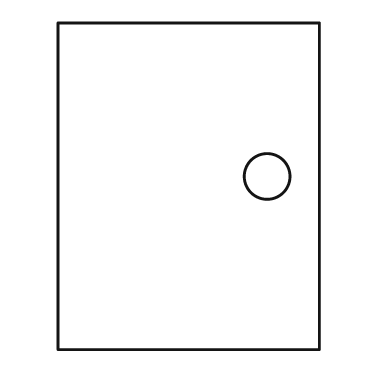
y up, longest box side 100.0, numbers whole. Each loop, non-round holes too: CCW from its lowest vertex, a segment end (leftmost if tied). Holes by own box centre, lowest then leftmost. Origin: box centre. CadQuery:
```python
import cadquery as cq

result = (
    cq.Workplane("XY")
    .moveTo(-40.0, -50.0)
    .lineTo(40.0, -50.0)
    .lineTo(40.0, 50.0)
    .lineTo(-40.0, 50.0)
    .close()
    .moveTo(24.0, 3.0)
    .circle(7.0)
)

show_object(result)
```